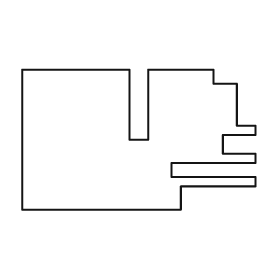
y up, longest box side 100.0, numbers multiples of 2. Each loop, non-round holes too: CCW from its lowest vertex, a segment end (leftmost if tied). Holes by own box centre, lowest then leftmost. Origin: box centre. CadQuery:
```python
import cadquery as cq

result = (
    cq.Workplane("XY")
    .moveTo(-50.0, -30.0)
    .lineTo(18.0, -30.0)
    .lineTo(18.0, -20.0)
    .lineTo(50.0, -20.0)
    .lineTo(50.0, -16.0)
    .lineTo(14.0, -16.0)
    .lineTo(14.0, -10.0)
    .lineTo(50.0, -10.0)
    .lineTo(50.0, -6.0)
    .lineTo(36.0, -6.0)
    .lineTo(36.0, 2.0)
    .lineTo(50.0, 2.0)
    .lineTo(50.0, 6.0)
    .lineTo(42.0, 6.0)
    .lineTo(42.0, 24.0)
    .lineTo(32.0, 24.0)
    .lineTo(32.0, 30.0)
    .lineTo(4.0, 30.0)
    .lineTo(4.0, 0.0)
    .lineTo(-4.0, 0.0)
    .lineTo(-4.0, 30.0)
    .lineTo(-50.0, 30.0)
    .close()
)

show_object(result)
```